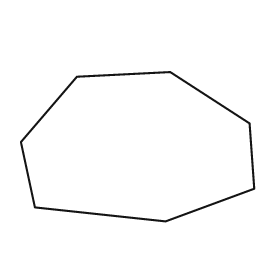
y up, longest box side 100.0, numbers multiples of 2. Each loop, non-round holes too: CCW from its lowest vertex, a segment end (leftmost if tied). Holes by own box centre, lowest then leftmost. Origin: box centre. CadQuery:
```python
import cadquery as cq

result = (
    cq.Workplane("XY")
    .moveTo(12.0, -32.0)
    .lineTo(50.0, -18.0)
    .lineTo(48.0, 10.0)
    .lineTo(14.0, 32.0)
    .lineTo(-26.0, 30.0)
    .lineTo(-50.0, 2.0)
    .lineTo(-44.0, -26.0)
    .close()
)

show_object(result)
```